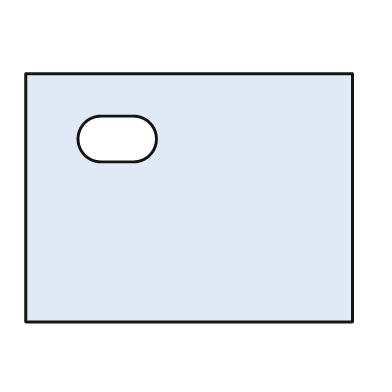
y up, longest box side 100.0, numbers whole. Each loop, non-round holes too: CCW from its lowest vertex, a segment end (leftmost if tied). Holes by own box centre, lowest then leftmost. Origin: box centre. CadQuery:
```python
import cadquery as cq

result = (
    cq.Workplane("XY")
    .moveTo(-50.0, -38.0)
    .lineTo(50.0, -38.0)
    .lineTo(50.0, 38.0)
    .lineTo(-50.0, 38.0)
    .close()
    .moveTo(-27.0, 11.0)
    .lineTo(-17.0, 11.0)
    .threePointArc((-10.0, 18.0), (-17.0, 25.0))
    .lineTo(-27.0, 25.0)
    .threePointArc((-34.0, 18.0), (-27.0, 11.0))
    .close()
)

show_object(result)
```